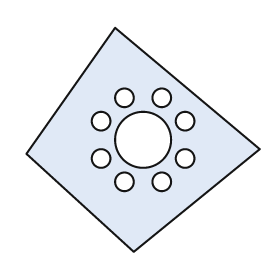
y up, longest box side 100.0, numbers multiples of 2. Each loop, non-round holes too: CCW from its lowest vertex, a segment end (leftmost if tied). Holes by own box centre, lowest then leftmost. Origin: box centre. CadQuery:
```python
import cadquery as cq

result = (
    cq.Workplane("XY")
    .moveTo(-4.0, -48.0)
    .lineTo(50.0, -4.0)
    .lineTo(-12.0, 48.0)
    .lineTo(-50.0, -6.0)
    .close()
    .moveTo(-8.0, -18.0)
    .circle(4.0)
    .moveTo(8.0, -18.0)
    .circle(4.0)
    .moveTo(-18.0, -8.0)
    .circle(4.0)
    .moveTo(18.0, -8.0)
    .circle(4.0)
    .moveTo(0.0, 0.0)
    .circle(12.0)
    .moveTo(-18.0, 8.0)
    .circle(4.0)
    .moveTo(18.0, 8.0)
    .circle(4.0)
    .moveTo(-8.0, 18.0)
    .circle(4.0)
    .moveTo(8.0, 18.0)
    .circle(4.0)
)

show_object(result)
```